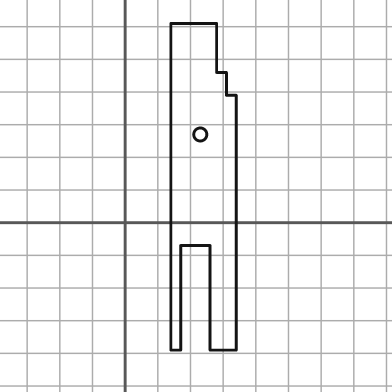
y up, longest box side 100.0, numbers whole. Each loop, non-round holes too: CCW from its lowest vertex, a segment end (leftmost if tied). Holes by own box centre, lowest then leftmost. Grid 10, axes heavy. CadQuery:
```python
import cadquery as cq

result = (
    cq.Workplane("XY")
    .moveTo(14.0, -39.0)
    .lineTo(17.0, -39.0)
    .lineTo(17.0, -7.0)
    .lineTo(26.0, -7.0)
    .lineTo(26.0, -39.0)
    .lineTo(34.0, -39.0)
    .lineTo(34.0, 39.0)
    .lineTo(31.0, 39.0)
    .lineTo(31.0, 46.0)
    .lineTo(28.0, 46.0)
    .lineTo(28.0, 61.0)
    .lineTo(14.0, 61.0)
    .close()
    .moveTo(23.0, 27.0)
    .circle(2.0)
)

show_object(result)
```